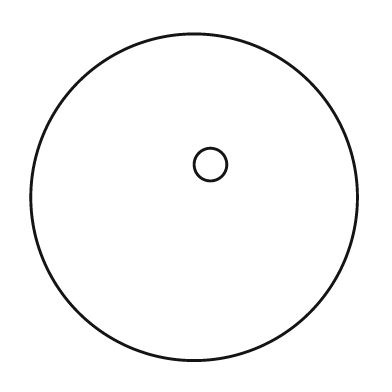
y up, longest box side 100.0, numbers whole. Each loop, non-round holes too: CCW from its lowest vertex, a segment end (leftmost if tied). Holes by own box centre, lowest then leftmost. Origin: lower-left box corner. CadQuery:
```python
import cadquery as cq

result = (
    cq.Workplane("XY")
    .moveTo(50.0, 50.0)
    .circle(50.0)
    .moveTo(55.0, 60.0)
    .circle(5.0)
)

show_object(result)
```